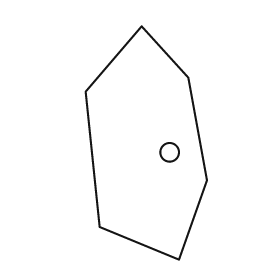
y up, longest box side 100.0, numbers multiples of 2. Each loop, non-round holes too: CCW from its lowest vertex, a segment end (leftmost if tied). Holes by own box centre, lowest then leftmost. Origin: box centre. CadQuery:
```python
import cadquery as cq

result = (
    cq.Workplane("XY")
    .moveTo(14.0, -50.0)
    .lineTo(26.0, -16.0)
    .lineTo(18.0, 28.0)
    .lineTo(-2.0, 50.0)
    .lineTo(-26.0, 22.0)
    .lineTo(-20.0, -36.0)
    .close()
    .moveTo(10.0, -4.0)
    .circle(4.0)
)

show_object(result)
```